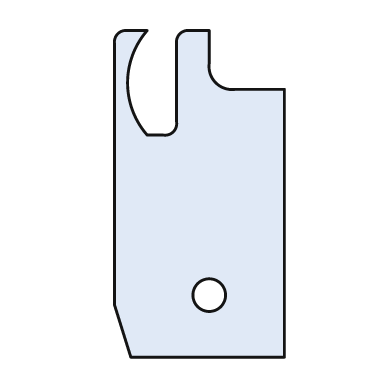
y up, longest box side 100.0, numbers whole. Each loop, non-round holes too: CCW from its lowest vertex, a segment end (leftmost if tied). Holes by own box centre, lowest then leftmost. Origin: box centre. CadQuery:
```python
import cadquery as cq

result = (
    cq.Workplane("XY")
    .moveTo(-21.0, -50.0)
    .lineTo(26.0, -50.0)
    .lineTo(26.0, 32.0)
    .lineTo(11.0, 32.0)
    .threePointArc((5.0, 34.0), (3.0, 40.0))
    .lineTo(3.0, 50.0)
    .lineTo(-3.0, 50.0)
    .threePointArc((-6.0, 49.0), (-7.0, 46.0))
    .lineTo(-7.0, 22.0)
    .threePointArc((-8.0, 19.0), (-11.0, 18.0))
    .lineTo(-16.0, 18.0)
    .threePointArc((-22.0, 34.0), (-16.0, 50.0))
    .lineTo(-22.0, 50.0)
    .threePointArc((-25.0, 49.0), (-26.0, 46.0))
    .lineTo(-26.0, -34.0)
    .close()
    .moveTo(3.0, -31.0)
    .circle(5.0)
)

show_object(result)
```